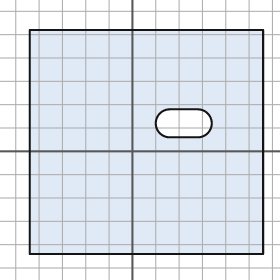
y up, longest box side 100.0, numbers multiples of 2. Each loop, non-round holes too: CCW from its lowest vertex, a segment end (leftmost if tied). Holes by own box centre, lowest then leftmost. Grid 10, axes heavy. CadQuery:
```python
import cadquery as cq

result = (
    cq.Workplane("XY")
    .moveTo(-44.0, -44.0)
    .lineTo(56.0, -44.0)
    .lineTo(56.0, 52.0)
    .lineTo(-44.0, 52.0)
    .close()
    .moveTo(16.0, 6.0)
    .lineTo(28.0, 6.0)
    .threePointArc((34.0, 12.0), (28.0, 18.0))
    .lineTo(16.0, 18.0)
    .threePointArc((10.0, 12.0), (16.0, 6.0))
    .close()
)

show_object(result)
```